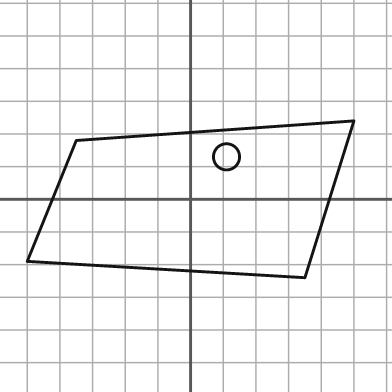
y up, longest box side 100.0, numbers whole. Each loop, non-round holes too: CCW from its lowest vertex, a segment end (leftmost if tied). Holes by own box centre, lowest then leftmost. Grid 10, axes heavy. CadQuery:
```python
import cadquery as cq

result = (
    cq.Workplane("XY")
    .moveTo(35.0, -24.0)
    .lineTo(50.0, 24.0)
    .lineTo(-35.0, 18.0)
    .lineTo(-50.0, -19.0)
    .close()
    .moveTo(11.0, 13.0)
    .circle(4.0)
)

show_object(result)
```